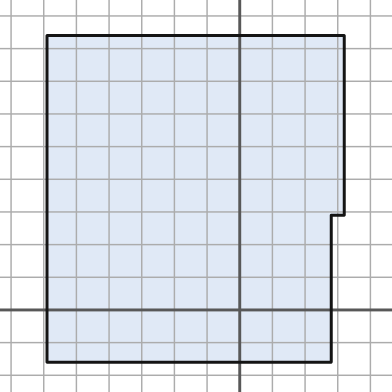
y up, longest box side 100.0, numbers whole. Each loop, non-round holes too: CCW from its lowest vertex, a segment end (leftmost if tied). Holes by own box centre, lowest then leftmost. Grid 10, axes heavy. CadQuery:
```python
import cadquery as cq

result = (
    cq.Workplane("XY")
    .moveTo(-59.0, -16.0)
    .lineTo(28.0, -16.0)
    .lineTo(28.0, 29.0)
    .lineTo(32.0, 29.0)
    .lineTo(32.0, 84.0)
    .lineTo(-59.0, 84.0)
    .close()
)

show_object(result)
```